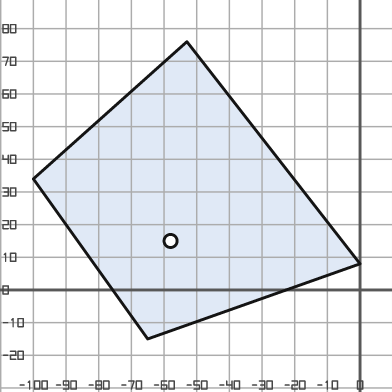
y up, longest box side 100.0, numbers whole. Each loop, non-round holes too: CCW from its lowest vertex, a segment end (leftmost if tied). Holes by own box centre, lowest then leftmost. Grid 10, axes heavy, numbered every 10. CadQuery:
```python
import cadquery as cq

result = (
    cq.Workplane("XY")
    .moveTo(-65.0, -15.0)
    .lineTo(0.0, 8.0)
    .lineTo(-53.0, 76.0)
    .lineTo(-100.0, 34.0)
    .close()
    .moveTo(-58.0, 15.0)
    .circle(2.0)
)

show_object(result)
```